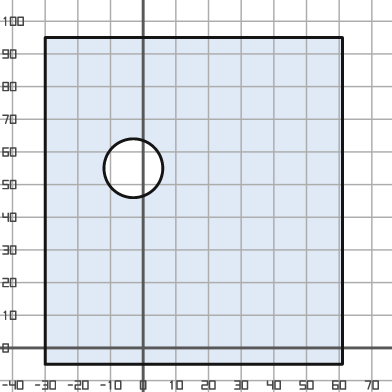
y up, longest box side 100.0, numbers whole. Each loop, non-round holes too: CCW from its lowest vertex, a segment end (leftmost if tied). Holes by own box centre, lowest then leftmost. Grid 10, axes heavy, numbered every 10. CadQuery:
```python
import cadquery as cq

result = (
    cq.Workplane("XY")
    .moveTo(-30.0, -5.0)
    .lineTo(61.0, -5.0)
    .lineTo(61.0, 95.0)
    .lineTo(-30.0, 95.0)
    .close()
    .moveTo(-3.0, 55.0)
    .circle(9.0)
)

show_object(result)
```